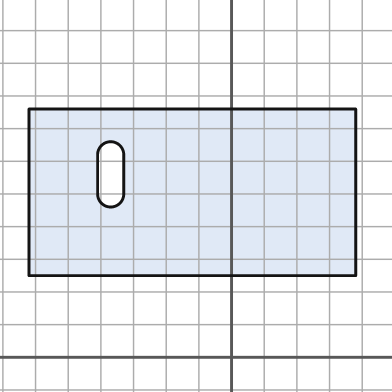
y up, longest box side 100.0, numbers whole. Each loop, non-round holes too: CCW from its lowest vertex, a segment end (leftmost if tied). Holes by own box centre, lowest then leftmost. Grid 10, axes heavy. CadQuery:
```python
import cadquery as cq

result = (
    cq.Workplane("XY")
    .moveTo(-62.0, 25.0)
    .lineTo(38.0, 25.0)
    .lineTo(38.0, 76.0)
    .lineTo(-62.0, 76.0)
    .close()
    .moveTo(-41.0, 50.0)
    .threePointArc((-37.0, 46.0), (-33.0, 50.0))
    .lineTo(-33.0, 62.0)
    .threePointArc((-37.0, 66.0), (-41.0, 62.0))
    .close()
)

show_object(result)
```